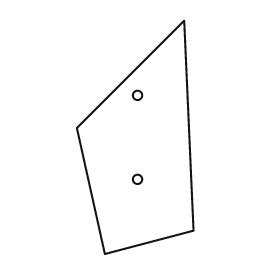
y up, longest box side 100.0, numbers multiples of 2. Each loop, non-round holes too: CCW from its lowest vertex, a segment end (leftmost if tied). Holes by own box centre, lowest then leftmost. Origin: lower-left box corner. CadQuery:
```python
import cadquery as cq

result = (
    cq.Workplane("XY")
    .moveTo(12.0, 0.0)
    .lineTo(50.0, 10.0)
    .lineTo(46.0, 100.0)
    .lineTo(0.0, 54.0)
    .close()
    .moveTo(26.0, 32.0)
    .circle(2.0)
    .moveTo(26.0, 68.0)
    .circle(2.0)
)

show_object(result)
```